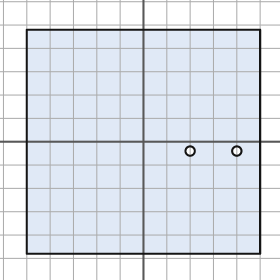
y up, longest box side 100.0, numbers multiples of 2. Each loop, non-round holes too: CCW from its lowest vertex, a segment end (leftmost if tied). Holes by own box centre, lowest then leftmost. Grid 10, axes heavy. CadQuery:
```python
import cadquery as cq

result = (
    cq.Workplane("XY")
    .moveTo(-50.0, -48.0)
    .lineTo(50.0, -48.0)
    .lineTo(50.0, 48.0)
    .lineTo(-50.0, 48.0)
    .close()
    .moveTo(20.0, -4.0)
    .circle(2.0)
    .moveTo(40.0, -4.0)
    .circle(2.0)
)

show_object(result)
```